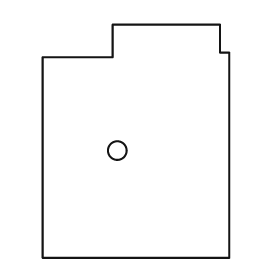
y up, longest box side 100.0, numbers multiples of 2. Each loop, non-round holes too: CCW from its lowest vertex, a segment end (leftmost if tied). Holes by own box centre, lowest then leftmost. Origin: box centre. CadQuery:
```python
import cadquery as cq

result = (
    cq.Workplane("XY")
    .moveTo(-40.0, -50.0)
    .lineTo(40.0, -50.0)
    .lineTo(40.0, 38.0)
    .lineTo(36.0, 38.0)
    .lineTo(36.0, 50.0)
    .lineTo(-10.0, 50.0)
    .lineTo(-10.0, 36.0)
    .lineTo(-40.0, 36.0)
    .close()
    .moveTo(-8.0, -4.0)
    .circle(4.0)
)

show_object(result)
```